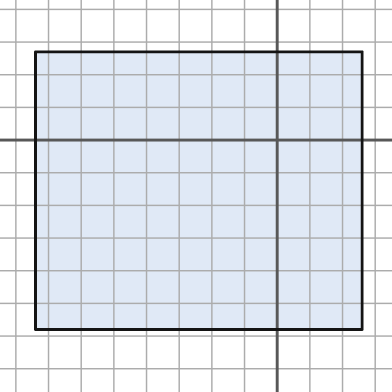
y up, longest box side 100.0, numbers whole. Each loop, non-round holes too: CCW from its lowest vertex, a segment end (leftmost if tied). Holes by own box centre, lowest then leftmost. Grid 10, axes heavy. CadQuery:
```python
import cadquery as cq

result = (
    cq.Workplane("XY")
    .moveTo(-74.0, -58.0)
    .lineTo(26.0, -58.0)
    .lineTo(26.0, 27.0)
    .lineTo(-74.0, 27.0)
    .close()
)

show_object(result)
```